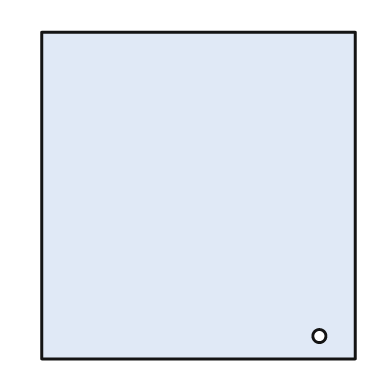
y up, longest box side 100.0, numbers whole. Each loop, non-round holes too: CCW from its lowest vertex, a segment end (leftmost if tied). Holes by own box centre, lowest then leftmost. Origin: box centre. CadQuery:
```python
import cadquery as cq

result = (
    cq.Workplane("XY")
    .moveTo(-48.0, -50.0)
    .lineTo(48.0, -50.0)
    .lineTo(48.0, 50.0)
    .lineTo(-48.0, 50.0)
    .close()
    .moveTo(37.0, -43.0)
    .circle(2.0)
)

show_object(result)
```